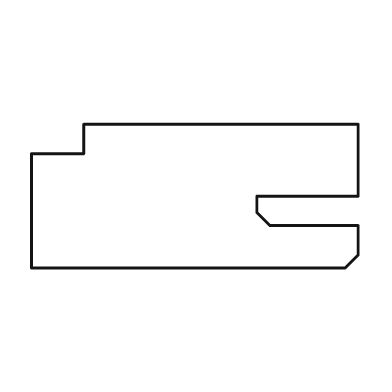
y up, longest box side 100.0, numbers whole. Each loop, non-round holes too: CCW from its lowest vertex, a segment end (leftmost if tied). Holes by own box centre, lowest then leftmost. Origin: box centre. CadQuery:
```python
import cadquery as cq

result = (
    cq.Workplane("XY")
    .moveTo(-50.0, -22.0)
    .lineTo(46.0, -22.0)
    .lineTo(50.0, -18.0)
    .lineTo(50.0, -9.0)
    .lineTo(23.0, -9.0)
    .lineTo(19.0, -5.0)
    .lineTo(19.0, 0.0)
    .lineTo(50.0, 0.0)
    .lineTo(50.0, 22.0)
    .lineTo(-34.0, 22.0)
    .lineTo(-34.0, 13.0)
    .lineTo(-50.0, 13.0)
    .close()
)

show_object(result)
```